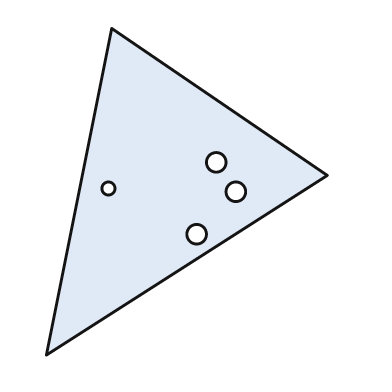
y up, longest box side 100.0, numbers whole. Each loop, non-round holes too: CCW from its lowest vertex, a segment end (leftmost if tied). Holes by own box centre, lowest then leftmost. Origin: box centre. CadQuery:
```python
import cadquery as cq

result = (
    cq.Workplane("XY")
    .moveTo(-43.0, -50.0)
    .lineTo(43.0, 5.0)
    .lineTo(-23.0, 50.0)
    .close()
    .moveTo(3.0, -13.0)
    .circle(3.0)
    .moveTo(15.0, 0.0)
    .circle(3.0)
    .moveTo(-24.0, 1.0)
    .circle(2.0)
    .moveTo(9.0, 9.0)
    .circle(3.0)
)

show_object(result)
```